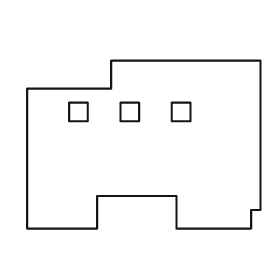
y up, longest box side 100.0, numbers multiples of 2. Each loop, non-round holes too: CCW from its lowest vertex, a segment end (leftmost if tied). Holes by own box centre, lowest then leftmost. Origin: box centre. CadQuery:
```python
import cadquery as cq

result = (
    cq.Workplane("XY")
    .moveTo(-50.0, -36.0)
    .lineTo(-20.0, -36.0)
    .lineTo(-20.0, -22.0)
    .lineTo(14.0, -22.0)
    .lineTo(14.0, -36.0)
    .lineTo(46.0, -36.0)
    .lineTo(46.0, -28.0)
    .lineTo(50.0, -28.0)
    .lineTo(50.0, 36.0)
    .lineTo(-14.0, 36.0)
    .lineTo(-14.0, 24.0)
    .lineTo(-50.0, 24.0)
    .close()
    .moveTo(-32.0, 10.0)
    .lineTo(-24.0, 10.0)
    .lineTo(-24.0, 18.0)
    .lineTo(-32.0, 18.0)
    .close()
    .moveTo(-10.0, 10.0)
    .lineTo(-2.0, 10.0)
    .lineTo(-2.0, 18.0)
    .lineTo(-10.0, 18.0)
    .close()
    .moveTo(12.0, 10.0)
    .lineTo(20.0, 10.0)
    .lineTo(20.0, 18.0)
    .lineTo(12.0, 18.0)
    .close()
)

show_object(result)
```